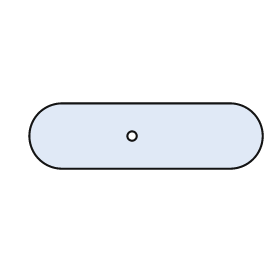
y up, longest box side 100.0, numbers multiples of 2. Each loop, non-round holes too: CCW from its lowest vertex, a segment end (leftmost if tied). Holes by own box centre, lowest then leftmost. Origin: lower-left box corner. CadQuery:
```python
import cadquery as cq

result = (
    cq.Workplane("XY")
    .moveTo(14.0, 0.0)
    .lineTo(86.0, 0.0)
    .threePointArc((100.0, 14.0), (86.0, 28.0))
    .lineTo(14.0, 28.0)
    .threePointArc((0.0, 14.0), (14.0, 0.0))
    .close()
    .moveTo(44.0, 14.0)
    .circle(2.0)
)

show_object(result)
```